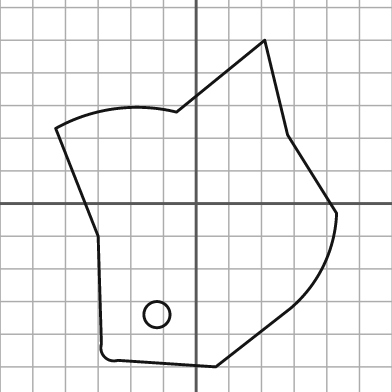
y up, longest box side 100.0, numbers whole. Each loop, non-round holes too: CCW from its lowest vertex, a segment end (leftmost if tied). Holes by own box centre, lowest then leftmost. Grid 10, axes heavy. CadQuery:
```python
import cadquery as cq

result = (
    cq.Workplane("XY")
    .moveTo(6.0, -50.0)
    .lineTo(29.0, -32.0)
    .threePointArc((39.0, -19.0), (43.0, -3.0))
    .lineTo(28.0, 21.0)
    .lineTo(21.0, 50.0)
    .lineTo(-6.0, 28.0)
    .threePointArc((-25.0, 29.0), (-43.0, 23.0))
    .lineTo(-30.0, -10.0)
    .lineTo(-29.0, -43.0)
    .threePointArc((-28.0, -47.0), (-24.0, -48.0))
    .close()
    .moveTo(-12.0, -34.0)
    .circle(4.0)
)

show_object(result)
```